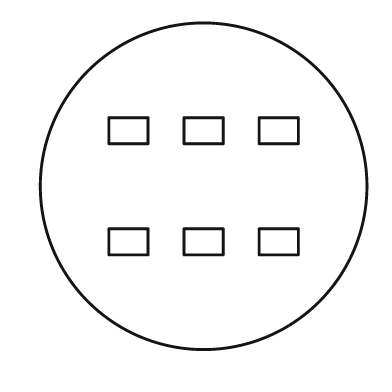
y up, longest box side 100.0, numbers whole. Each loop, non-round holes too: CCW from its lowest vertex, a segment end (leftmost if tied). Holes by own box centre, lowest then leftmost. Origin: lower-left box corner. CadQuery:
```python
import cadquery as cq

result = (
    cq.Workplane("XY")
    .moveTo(50.0, 50.0)
    .circle(50.0)
    .moveTo(21.0, 29.0)
    .lineTo(33.0, 29.0)
    .lineTo(33.0, 37.0)
    .lineTo(21.0, 37.0)
    .close()
    .moveTo(44.0, 29.0)
    .lineTo(56.0, 29.0)
    .lineTo(56.0, 37.0)
    .lineTo(44.0, 37.0)
    .close()
    .moveTo(67.0, 29.0)
    .lineTo(79.0, 29.0)
    .lineTo(79.0, 37.0)
    .lineTo(67.0, 37.0)
    .close()
    .moveTo(21.0, 63.0)
    .lineTo(33.0, 63.0)
    .lineTo(33.0, 71.0)
    .lineTo(21.0, 71.0)
    .close()
    .moveTo(44.0, 63.0)
    .lineTo(56.0, 63.0)
    .lineTo(56.0, 71.0)
    .lineTo(44.0, 71.0)
    .close()
    .moveTo(67.0, 63.0)
    .lineTo(79.0, 63.0)
    .lineTo(79.0, 71.0)
    .lineTo(67.0, 71.0)
    .close()
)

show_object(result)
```